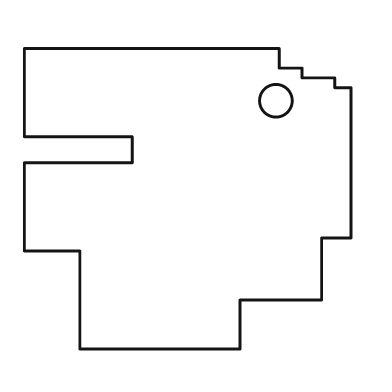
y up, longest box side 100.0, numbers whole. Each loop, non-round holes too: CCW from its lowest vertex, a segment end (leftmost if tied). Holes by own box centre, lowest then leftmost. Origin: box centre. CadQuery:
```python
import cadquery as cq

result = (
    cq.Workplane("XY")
    .moveTo(-33.0, -46.0)
    .lineTo(16.0, -46.0)
    .lineTo(16.0, -31.0)
    .lineTo(41.0, -31.0)
    .lineTo(41.0, -12.0)
    .lineTo(50.0, -12.0)
    .lineTo(50.0, 34.0)
    .lineTo(45.0, 34.0)
    .lineTo(45.0, 37.0)
    .lineTo(35.0, 37.0)
    .lineTo(35.0, 40.0)
    .lineTo(28.0, 40.0)
    .lineTo(28.0, 46.0)
    .lineTo(-50.0, 46.0)
    .lineTo(-50.0, 19.0)
    .lineTo(-17.0, 19.0)
    .lineTo(-17.0, 11.0)
    .lineTo(-50.0, 11.0)
    .lineTo(-50.0, -16.0)
    .lineTo(-33.0, -16.0)
    .close()
    .moveTo(27.0, 30.0)
    .circle(5.0)
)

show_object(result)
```